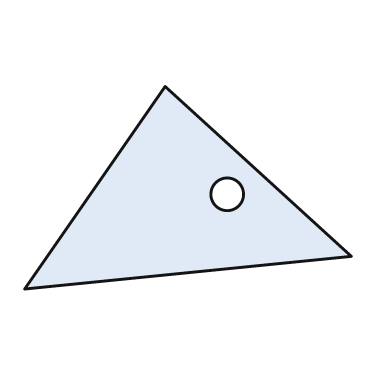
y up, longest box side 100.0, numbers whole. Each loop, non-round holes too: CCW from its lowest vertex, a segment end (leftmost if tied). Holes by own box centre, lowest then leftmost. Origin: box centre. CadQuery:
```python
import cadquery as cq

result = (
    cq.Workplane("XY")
    .moveTo(-50.0, -31.0)
    .lineTo(50.0, -21.0)
    .lineTo(-7.0, 31.0)
    .close()
    .moveTo(12.0, -2.0)
    .circle(5.0)
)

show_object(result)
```